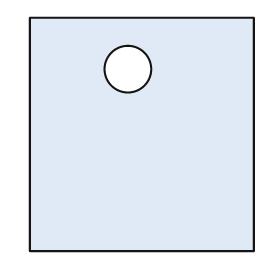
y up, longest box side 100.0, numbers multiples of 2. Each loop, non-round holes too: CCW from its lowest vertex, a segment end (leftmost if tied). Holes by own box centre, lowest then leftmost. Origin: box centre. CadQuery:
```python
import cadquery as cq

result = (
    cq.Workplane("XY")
    .moveTo(-48.0, -50.0)
    .lineTo(48.0, -50.0)
    .lineTo(48.0, 50.0)
    .lineTo(-48.0, 50.0)
    .close()
    .moveTo(-6.0, 28.0)
    .circle(10.0)
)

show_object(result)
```